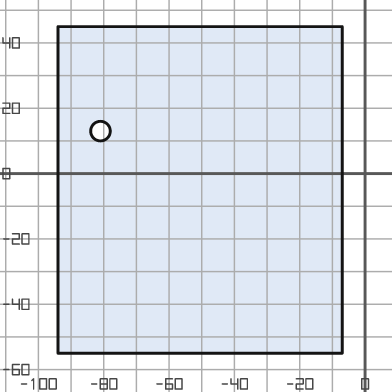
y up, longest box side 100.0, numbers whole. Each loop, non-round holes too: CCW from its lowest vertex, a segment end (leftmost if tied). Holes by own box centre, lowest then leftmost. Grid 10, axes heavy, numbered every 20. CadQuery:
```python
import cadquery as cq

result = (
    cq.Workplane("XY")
    .moveTo(-94.0, -55.0)
    .lineTo(-7.0, -55.0)
    .lineTo(-7.0, 45.0)
    .lineTo(-94.0, 45.0)
    .close()
    .moveTo(-81.0, 13.0)
    .circle(3.0)
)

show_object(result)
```